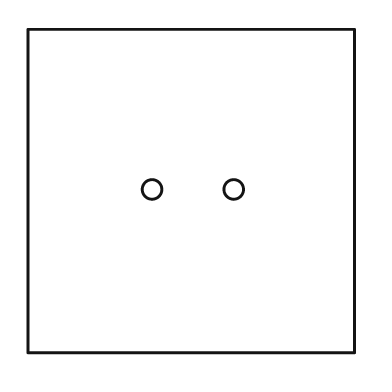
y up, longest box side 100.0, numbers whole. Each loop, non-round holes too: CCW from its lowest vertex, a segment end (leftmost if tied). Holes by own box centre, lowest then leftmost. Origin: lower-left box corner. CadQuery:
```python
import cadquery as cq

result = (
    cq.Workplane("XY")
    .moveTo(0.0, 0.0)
    .lineTo(100.0, 0.0)
    .lineTo(100.0, 99.0)
    .lineTo(0.0, 99.0)
    .close()
    .moveTo(38.0, 50.0)
    .circle(3.0)
    .moveTo(63.0, 50.0)
    .circle(3.0)
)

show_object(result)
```